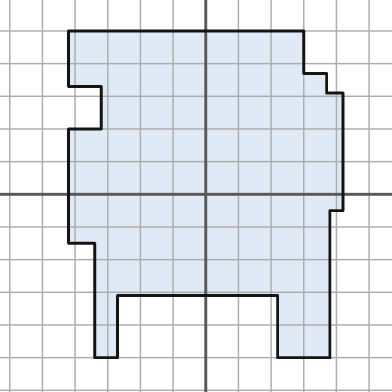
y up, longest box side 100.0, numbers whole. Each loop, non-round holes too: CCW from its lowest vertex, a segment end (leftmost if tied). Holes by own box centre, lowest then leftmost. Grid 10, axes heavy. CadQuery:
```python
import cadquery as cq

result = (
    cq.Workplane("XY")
    .moveTo(-34.0, -50.0)
    .lineTo(-27.0, -50.0)
    .lineTo(-27.0, -31.0)
    .lineTo(22.0, -31.0)
    .lineTo(22.0, -50.0)
    .lineTo(38.0, -50.0)
    .lineTo(38.0, -5.0)
    .lineTo(42.0, -5.0)
    .lineTo(42.0, 31.0)
    .lineTo(37.0, 31.0)
    .lineTo(37.0, 37.0)
    .lineTo(30.0, 37.0)
    .lineTo(30.0, 50.0)
    .lineTo(-42.0, 50.0)
    .lineTo(-42.0, 33.0)
    .lineTo(-32.0, 33.0)
    .lineTo(-32.0, 20.0)
    .lineTo(-42.0, 20.0)
    .lineTo(-42.0, -15.0)
    .lineTo(-34.0, -15.0)
    .close()
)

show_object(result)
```